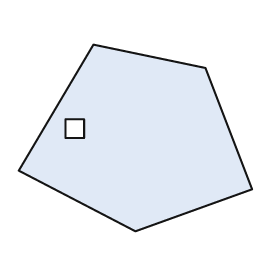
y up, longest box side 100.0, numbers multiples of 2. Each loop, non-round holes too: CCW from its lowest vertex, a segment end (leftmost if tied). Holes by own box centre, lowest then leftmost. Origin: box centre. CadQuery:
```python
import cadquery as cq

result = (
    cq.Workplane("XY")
    .moveTo(0.0, -40.0)
    .lineTo(50.0, -22.0)
    .lineTo(30.0, 30.0)
    .lineTo(-18.0, 40.0)
    .lineTo(-50.0, -14.0)
    .close()
    .moveTo(-30.0, 0.0)
    .lineTo(-22.0, 0.0)
    .lineTo(-22.0, 8.0)
    .lineTo(-30.0, 8.0)
    .close()
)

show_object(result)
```